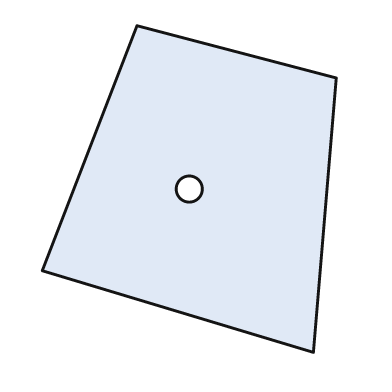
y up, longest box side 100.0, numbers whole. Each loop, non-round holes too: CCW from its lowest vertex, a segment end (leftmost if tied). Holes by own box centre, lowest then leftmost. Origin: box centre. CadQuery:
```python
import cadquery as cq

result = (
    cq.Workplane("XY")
    .moveTo(38.0, -50.0)
    .lineTo(45.0, 34.0)
    .lineTo(-16.0, 50.0)
    .lineTo(-45.0, -25.0)
    .close()
    .moveTo(0.0, 0.0)
    .circle(4.0)
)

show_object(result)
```